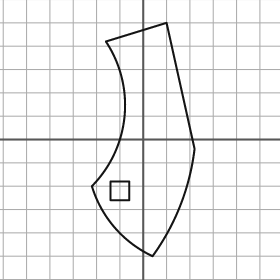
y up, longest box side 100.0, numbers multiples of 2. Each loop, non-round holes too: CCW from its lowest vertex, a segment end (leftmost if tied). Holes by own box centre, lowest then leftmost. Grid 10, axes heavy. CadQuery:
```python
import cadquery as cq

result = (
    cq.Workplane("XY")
    .moveTo(4.0, -50.0)
    .threePointArc((16.0, -28.0), (22.0, -4.0))
    .lineTo(10.0, 50.0)
    .lineTo(-16.0, 42.0)
    .threePointArc((-8.0, 10.0), (-22.0, -20.0))
    .threePointArc((-12.0, -38.0), (4.0, -50.0))
    .close()
    .moveTo(-14.0, -26.0)
    .lineTo(-6.0, -26.0)
    .lineTo(-6.0, -18.0)
    .lineTo(-14.0, -18.0)
    .close()
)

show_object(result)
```